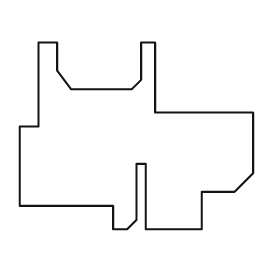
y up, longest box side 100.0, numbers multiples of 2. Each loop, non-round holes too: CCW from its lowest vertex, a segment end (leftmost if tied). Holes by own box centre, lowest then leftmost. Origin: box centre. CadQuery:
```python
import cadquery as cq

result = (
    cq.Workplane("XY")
    .moveTo(-10.0, -40.0)
    .lineTo(-4.0, -40.0)
    .lineTo(0.0, -36.0)
    .lineTo(0.0, -12.0)
    .lineTo(4.0, -12.0)
    .lineTo(4.0, -40.0)
    .lineTo(28.0, -40.0)
    .lineTo(28.0, -24.0)
    .lineTo(42.0, -24.0)
    .lineTo(50.0, -16.0)
    .lineTo(50.0, 10.0)
    .lineTo(8.0, 10.0)
    .lineTo(8.0, 40.0)
    .lineTo(2.0, 40.0)
    .lineTo(2.0, 24.0)
    .lineTo(-2.0, 20.0)
    .lineTo(-28.0, 20.0)
    .lineTo(-34.0, 28.0)
    .lineTo(-34.0, 40.0)
    .lineTo(-42.0, 40.0)
    .lineTo(-42.0, 4.0)
    .lineTo(-50.0, 4.0)
    .lineTo(-50.0, -30.0)
    .lineTo(-10.0, -30.0)
    .close()
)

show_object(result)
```